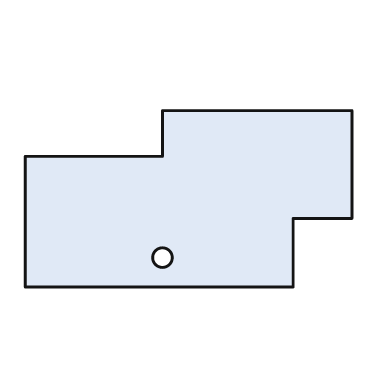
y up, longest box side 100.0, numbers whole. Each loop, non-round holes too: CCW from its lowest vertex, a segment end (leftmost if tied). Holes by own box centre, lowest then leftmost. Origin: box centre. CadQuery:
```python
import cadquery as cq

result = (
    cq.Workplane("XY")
    .moveTo(-50.0, -27.0)
    .lineTo(32.0, -27.0)
    .lineTo(32.0, -6.0)
    .lineTo(50.0, -6.0)
    .lineTo(50.0, 27.0)
    .lineTo(-8.0, 27.0)
    .lineTo(-8.0, 13.0)
    .lineTo(-50.0, 13.0)
    .close()
    .moveTo(-8.0, -18.0)
    .circle(3.0)
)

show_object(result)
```